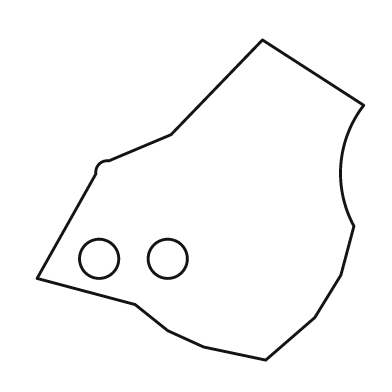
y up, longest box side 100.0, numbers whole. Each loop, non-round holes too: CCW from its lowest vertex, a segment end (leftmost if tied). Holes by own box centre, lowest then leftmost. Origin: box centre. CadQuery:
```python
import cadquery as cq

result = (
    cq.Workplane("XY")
    .moveTo(20.0, -49.0)
    .lineTo(35.0, -36.0)
    .lineTo(43.0, -23.0)
    .lineTo(47.0, -8.0)
    .threePointArc((43.0, 11.0), (50.0, 29.0))
    .lineTo(19.0, 49.0)
    .lineTo(-9.0, 20.0)
    .lineTo(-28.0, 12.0)
    .threePointArc((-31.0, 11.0), (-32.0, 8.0))
    .lineTo(-50.0, -24.0)
    .lineTo(-20.0, -32.0)
    .lineTo(-10.0, -40.0)
    .lineTo(1.0, -45.0)
    .close()
    .moveTo(-31.0, -18.0)
    .circle(6.0)
    .moveTo(-10.0, -18.0)
    .circle(6.0)
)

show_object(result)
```